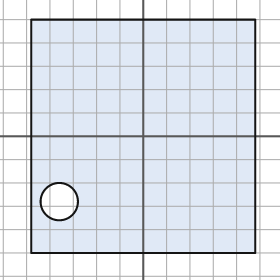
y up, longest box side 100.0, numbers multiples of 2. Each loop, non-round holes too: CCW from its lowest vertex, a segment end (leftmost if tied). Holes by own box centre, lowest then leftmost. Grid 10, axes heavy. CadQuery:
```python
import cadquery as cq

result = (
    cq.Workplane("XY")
    .moveTo(-48.0, -50.0)
    .lineTo(48.0, -50.0)
    .lineTo(48.0, 50.0)
    .lineTo(-48.0, 50.0)
    .close()
    .moveTo(-36.0, -28.0)
    .circle(8.0)
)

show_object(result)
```